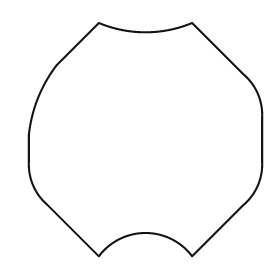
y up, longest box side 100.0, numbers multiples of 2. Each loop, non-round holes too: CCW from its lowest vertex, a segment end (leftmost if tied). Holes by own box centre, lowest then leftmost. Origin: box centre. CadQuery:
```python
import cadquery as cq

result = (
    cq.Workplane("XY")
    .moveTo(-20.0, -50.0)
    .threePointArc((0.0, -40.0), (20.0, -50.0))
    .lineTo(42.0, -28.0)
    .threePointArc((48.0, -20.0), (50.0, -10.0))
    .lineTo(50.0, 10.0)
    .threePointArc((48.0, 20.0), (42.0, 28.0))
    .lineTo(20.0, 50.0)
    .threePointArc((0.0, 46.0), (-20.0, 50.0))
    .lineTo(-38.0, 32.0)
    .threePointArc((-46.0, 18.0), (-50.0, 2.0))
    .lineTo(-50.0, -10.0)
    .threePointArc((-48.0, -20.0), (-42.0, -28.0))
    .close()
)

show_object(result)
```